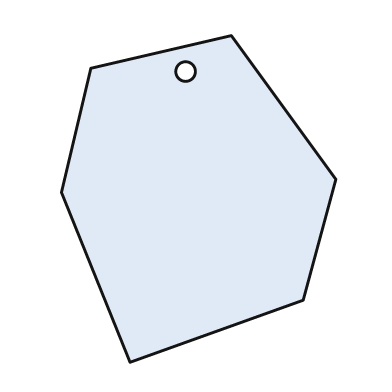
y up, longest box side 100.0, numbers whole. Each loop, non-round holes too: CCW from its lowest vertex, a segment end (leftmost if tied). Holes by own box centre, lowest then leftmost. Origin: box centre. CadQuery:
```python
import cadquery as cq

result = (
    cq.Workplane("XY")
    .moveTo(-21.0, -50.0)
    .lineTo(32.0, -31.0)
    .lineTo(42.0, 6.0)
    .lineTo(10.0, 50.0)
    .lineTo(-33.0, 40.0)
    .lineTo(-42.0, 2.0)
    .close()
    .moveTo(-4.0, 39.0)
    .circle(3.0)
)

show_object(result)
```